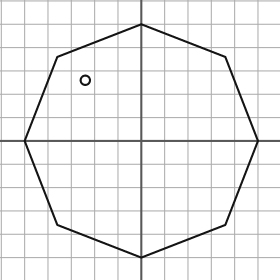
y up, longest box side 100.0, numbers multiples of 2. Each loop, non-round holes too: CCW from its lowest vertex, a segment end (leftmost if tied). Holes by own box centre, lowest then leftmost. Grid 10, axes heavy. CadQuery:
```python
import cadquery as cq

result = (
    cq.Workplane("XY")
    .moveTo(0.0, -50.0)
    .lineTo(36.0, -36.0)
    .lineTo(50.0, 0.0)
    .lineTo(36.0, 36.0)
    .lineTo(0.0, 50.0)
    .lineTo(-36.0, 36.0)
    .lineTo(-50.0, 0.0)
    .lineTo(-36.0, -36.0)
    .close()
    .moveTo(-24.0, 26.0)
    .circle(2.0)
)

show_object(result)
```